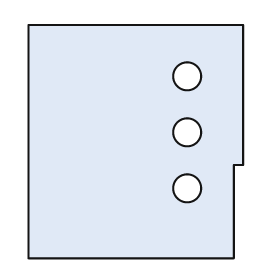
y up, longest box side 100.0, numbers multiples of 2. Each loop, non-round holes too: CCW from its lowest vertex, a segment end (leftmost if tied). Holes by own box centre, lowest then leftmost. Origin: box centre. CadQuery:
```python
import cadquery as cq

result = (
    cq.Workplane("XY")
    .moveTo(-46.0, -50.0)
    .lineTo(42.0, -50.0)
    .lineTo(42.0, -10.0)
    .lineTo(46.0, -10.0)
    .lineTo(46.0, 50.0)
    .lineTo(-46.0, 50.0)
    .close()
    .moveTo(22.0, -20.0)
    .circle(6.0)
    .moveTo(22.0, 4.0)
    .circle(6.0)
    .moveTo(22.0, 28.0)
    .circle(6.0)
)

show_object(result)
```